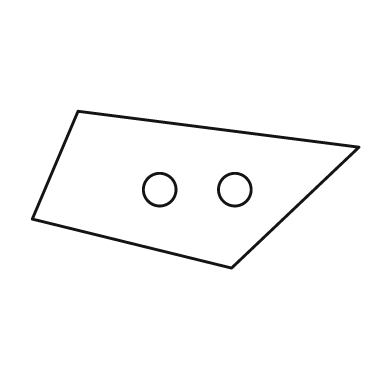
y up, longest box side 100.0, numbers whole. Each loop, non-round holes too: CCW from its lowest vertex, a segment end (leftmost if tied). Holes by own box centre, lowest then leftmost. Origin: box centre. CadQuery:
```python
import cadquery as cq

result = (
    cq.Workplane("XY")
    .moveTo(11.0, -24.0)
    .lineTo(50.0, 13.0)
    .lineTo(-36.0, 24.0)
    .lineTo(-50.0, -9.0)
    .close()
    .moveTo(-11.0, 0.0)
    .circle(5.0)
    .moveTo(12.0, 0.0)
    .circle(5.0)
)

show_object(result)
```